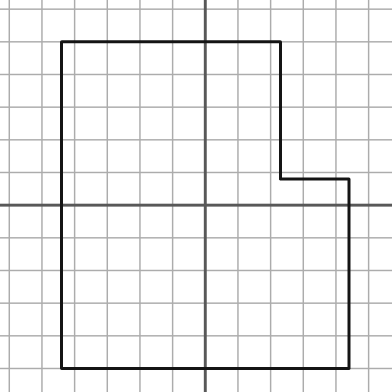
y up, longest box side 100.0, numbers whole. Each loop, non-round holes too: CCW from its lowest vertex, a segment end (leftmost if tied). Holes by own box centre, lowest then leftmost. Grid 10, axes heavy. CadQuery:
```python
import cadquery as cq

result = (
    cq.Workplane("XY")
    .moveTo(-44.0, -50.0)
    .lineTo(44.0, -50.0)
    .lineTo(44.0, 8.0)
    .lineTo(23.0, 8.0)
    .lineTo(23.0, 50.0)
    .lineTo(-44.0, 50.0)
    .close()
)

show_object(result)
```